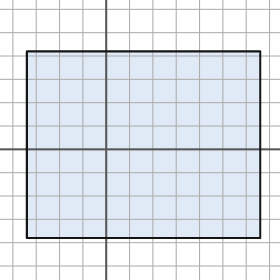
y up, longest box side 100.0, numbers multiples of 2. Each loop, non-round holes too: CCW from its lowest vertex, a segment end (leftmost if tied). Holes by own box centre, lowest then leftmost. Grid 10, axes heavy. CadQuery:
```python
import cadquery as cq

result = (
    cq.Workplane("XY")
    .moveTo(-34.0, -38.0)
    .lineTo(66.0, -38.0)
    .lineTo(66.0, 42.0)
    .lineTo(-34.0, 42.0)
    .close()
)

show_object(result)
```